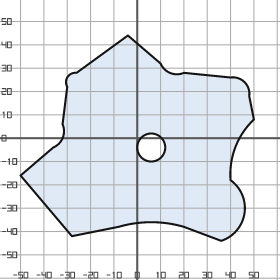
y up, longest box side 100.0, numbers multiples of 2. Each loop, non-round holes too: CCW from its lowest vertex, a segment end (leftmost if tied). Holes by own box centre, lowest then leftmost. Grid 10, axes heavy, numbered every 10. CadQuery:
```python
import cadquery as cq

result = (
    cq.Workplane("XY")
    .moveTo(36.0, -44.0)
    .threePointArc((46.0, -32.0), (40.0, -18.0))
    .threePointArc((42.0, -4.0), (50.0, 8.0))
    .lineTo(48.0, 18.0)
    .threePointArc((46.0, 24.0), (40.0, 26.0))
    .lineTo(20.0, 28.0)
    .threePointArc((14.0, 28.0), (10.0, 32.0))
    .lineTo(-4.0, 44.0)
    .lineTo(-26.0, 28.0)
    .threePointArc((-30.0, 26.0), (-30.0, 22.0))
    .lineTo(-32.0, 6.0)
    .threePointArc((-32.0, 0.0), (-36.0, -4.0))
    .lineTo(-50.0, -16.0)
    .lineTo(-28.0, -42.0)
    .lineTo(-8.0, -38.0)
    .threePointArc((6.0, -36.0), (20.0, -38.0))
    .close()
    .moveTo(6.0, -4.0)
    .circle(6.0)
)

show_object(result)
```